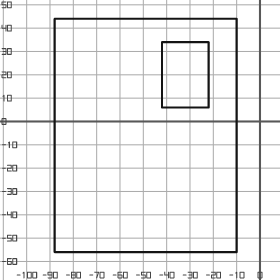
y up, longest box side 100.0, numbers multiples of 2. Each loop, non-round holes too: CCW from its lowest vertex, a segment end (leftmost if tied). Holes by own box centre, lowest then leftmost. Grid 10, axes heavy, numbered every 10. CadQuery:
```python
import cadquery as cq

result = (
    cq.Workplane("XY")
    .moveTo(-88.0, -56.0)
    .lineTo(-10.0, -56.0)
    .lineTo(-10.0, 44.0)
    .lineTo(-88.0, 44.0)
    .close()
    .moveTo(-42.0, 6.0)
    .lineTo(-22.0, 6.0)
    .lineTo(-22.0, 34.0)
    .lineTo(-42.0, 34.0)
    .close()
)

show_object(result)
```